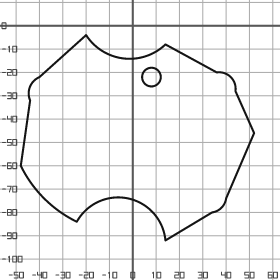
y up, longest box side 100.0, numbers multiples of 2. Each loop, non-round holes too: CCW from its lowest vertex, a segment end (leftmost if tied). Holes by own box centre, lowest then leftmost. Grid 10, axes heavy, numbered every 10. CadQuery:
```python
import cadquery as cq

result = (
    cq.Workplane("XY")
    .moveTo(14.0, -92.0)
    .lineTo(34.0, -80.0)
    .threePointArc((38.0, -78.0), (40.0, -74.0))
    .lineTo(52.0, -46.0)
    .lineTo(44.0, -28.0)
    .threePointArc((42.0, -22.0), (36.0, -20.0))
    .lineTo(14.0, -8.0)
    .threePointArc((-4.0, -14.0), (-20.0, -4.0))
    .lineTo(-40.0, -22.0)
    .threePointArc((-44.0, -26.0), (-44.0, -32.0))
    .lineTo(-48.0, -60.0)
    .threePointArc((-38.0, -74.0), (-24.0, -84.0))
    .threePointArc((-2.0, -74.0), (14.0, -92.0))
    .close()
    .moveTo(8.0, -22.0)
    .circle(4.0)
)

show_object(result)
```